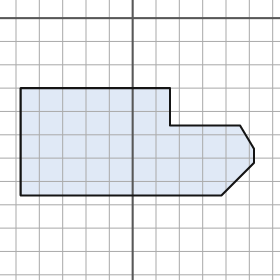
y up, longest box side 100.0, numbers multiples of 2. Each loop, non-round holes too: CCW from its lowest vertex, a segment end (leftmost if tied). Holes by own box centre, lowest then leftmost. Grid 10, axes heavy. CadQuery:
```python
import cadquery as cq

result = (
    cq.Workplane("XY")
    .moveTo(-48.0, -76.0)
    .lineTo(38.0, -76.0)
    .lineTo(52.0, -62.0)
    .lineTo(52.0, -56.0)
    .lineTo(46.0, -46.0)
    .lineTo(16.0, -46.0)
    .lineTo(16.0, -30.0)
    .lineTo(-48.0, -30.0)
    .close()
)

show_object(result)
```